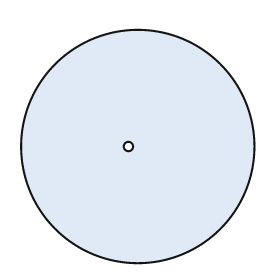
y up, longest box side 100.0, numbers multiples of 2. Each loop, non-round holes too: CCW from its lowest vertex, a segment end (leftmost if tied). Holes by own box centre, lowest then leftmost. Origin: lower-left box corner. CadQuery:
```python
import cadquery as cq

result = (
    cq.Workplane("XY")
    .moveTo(50.0, 50.0)
    .circle(50.0)
    .moveTo(46.0, 50.0)
    .circle(2.0)
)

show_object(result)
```